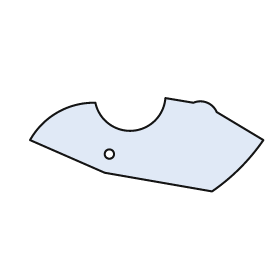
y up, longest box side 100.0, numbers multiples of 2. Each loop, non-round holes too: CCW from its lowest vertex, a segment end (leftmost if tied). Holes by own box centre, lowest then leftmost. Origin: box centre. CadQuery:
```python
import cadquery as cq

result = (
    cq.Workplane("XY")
    .moveTo(28.0, -20.0)
    .threePointArc((40.0, -10.0), (50.0, 2.0))
    .lineTo(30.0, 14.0)
    .threePointArc((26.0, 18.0), (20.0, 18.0))
    .lineTo(8.0, 20.0)
    .threePointArc((-6.0, 6.0), (-22.0, 18.0))
    .threePointArc((-38.0, 14.0), (-50.0, 2.0))
    .lineTo(-18.0, -12.0)
    .close()
    .moveTo(-16.0, -4.0)
    .circle(2.0)
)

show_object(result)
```